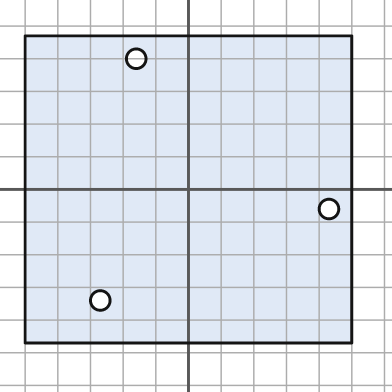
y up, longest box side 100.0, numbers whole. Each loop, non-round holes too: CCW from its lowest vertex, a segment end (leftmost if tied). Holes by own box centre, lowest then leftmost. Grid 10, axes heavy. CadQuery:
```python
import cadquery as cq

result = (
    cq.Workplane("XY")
    .moveTo(-50.0, -47.0)
    .lineTo(50.0, -47.0)
    .lineTo(50.0, 47.0)
    .lineTo(-50.0, 47.0)
    .close()
    .moveTo(-27.0, -34.0)
    .circle(3.0)
    .moveTo(43.0, -6.0)
    .circle(3.0)
    .moveTo(-16.0, 40.0)
    .circle(3.0)
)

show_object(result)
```